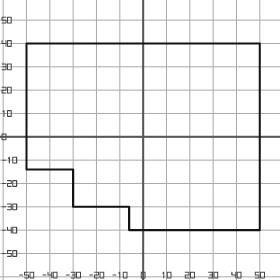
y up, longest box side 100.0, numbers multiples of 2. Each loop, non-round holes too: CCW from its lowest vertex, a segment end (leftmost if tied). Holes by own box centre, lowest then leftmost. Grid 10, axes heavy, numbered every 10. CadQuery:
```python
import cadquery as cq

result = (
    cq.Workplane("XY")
    .moveTo(-6.0, -40.0)
    .lineTo(50.0, -40.0)
    .lineTo(50.0, 40.0)
    .lineTo(-50.0, 40.0)
    .lineTo(-50.0, -14.0)
    .lineTo(-30.0, -14.0)
    .lineTo(-30.0, -30.0)
    .lineTo(-6.0, -30.0)
    .close()
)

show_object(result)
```